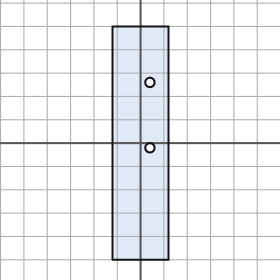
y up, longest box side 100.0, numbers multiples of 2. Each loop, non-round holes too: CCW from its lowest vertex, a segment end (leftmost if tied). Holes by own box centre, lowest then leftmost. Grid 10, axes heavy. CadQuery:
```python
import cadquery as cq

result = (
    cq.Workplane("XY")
    .moveTo(-12.0, -50.0)
    .lineTo(12.0, -50.0)
    .lineTo(12.0, 50.0)
    .lineTo(-12.0, 50.0)
    .close()
    .moveTo(4.0, -2.0)
    .circle(2.0)
    .moveTo(4.0, 26.0)
    .circle(2.0)
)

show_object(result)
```